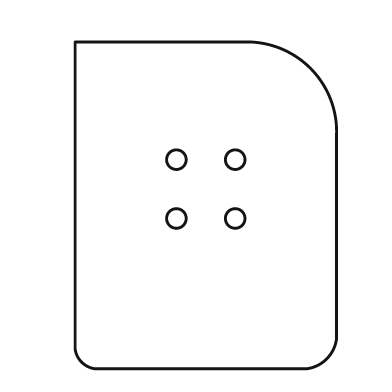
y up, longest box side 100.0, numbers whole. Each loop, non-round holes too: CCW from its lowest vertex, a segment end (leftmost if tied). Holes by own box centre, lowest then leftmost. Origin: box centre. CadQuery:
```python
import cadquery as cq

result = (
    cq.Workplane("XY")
    .moveTo(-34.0, -50.0)
    .lineTo(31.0, -50.0)
    .threePointArc((37.0, -47.0), (40.0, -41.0))
    .lineTo(40.0, 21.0)
    .threePointArc((32.0, 42.0), (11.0, 50.0))
    .lineTo(-40.0, 50.0)
    .lineTo(-40.0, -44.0)
    .threePointArc((-38.0, -48.0), (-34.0, -50.0))
    .close()
    .moveTo(-9.0, -4.0)
    .circle(3.0)
    .moveTo(9.0, -4.0)
    .circle(3.0)
    .moveTo(-9.0, 14.0)
    .circle(3.0)
    .moveTo(9.0, 14.0)
    .circle(3.0)
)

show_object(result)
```